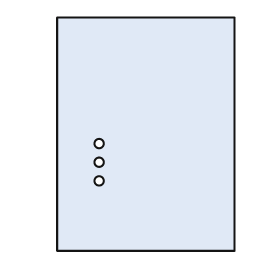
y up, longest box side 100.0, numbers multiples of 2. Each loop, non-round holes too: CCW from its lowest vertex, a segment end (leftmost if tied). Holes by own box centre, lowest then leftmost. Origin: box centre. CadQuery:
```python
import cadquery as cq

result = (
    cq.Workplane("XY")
    .moveTo(-38.0, -50.0)
    .lineTo(38.0, -50.0)
    .lineTo(38.0, 50.0)
    .lineTo(-38.0, 50.0)
    .close()
    .moveTo(-20.0, -20.0)
    .circle(2.0)
    .moveTo(-20.0, -12.0)
    .circle(2.0)
    .moveTo(-20.0, -4.0)
    .circle(2.0)
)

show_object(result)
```